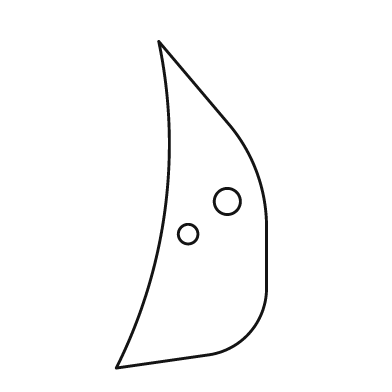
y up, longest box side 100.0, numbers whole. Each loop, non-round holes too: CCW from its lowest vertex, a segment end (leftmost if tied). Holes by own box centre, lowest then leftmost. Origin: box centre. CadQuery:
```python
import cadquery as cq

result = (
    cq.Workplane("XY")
    .moveTo(-23.0, -50.0)
    .lineTo(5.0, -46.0)
    .threePointArc((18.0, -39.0), (23.0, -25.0))
    .lineTo(23.0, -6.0)
    .threePointArc((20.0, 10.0), (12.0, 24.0))
    .lineTo(-10.0, 50.0)
    .threePointArc((-8.0, -1.0), (-23.0, -50.0))
    .close()
    .moveTo(-1.0, -9.0)
    .circle(3.0)
    .moveTo(11.0, 1.0)
    .circle(4.0)
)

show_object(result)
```